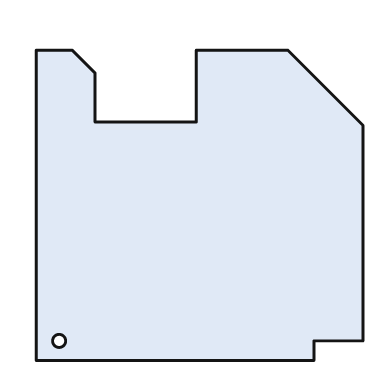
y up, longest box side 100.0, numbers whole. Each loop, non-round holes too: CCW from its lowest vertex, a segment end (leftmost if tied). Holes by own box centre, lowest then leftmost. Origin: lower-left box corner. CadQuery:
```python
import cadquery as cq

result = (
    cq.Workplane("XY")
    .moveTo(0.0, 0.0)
    .lineTo(85.0, 0.0)
    .lineTo(85.0, 6.0)
    .lineTo(100.0, 6.0)
    .lineTo(100.0, 72.0)
    .lineTo(77.0, 95.0)
    .lineTo(49.0, 95.0)
    .lineTo(49.0, 73.0)
    .lineTo(18.0, 73.0)
    .lineTo(18.0, 88.0)
    .lineTo(11.0, 95.0)
    .lineTo(0.0, 95.0)
    .close()
    .moveTo(7.0, 6.0)
    .circle(2.0)
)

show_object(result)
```